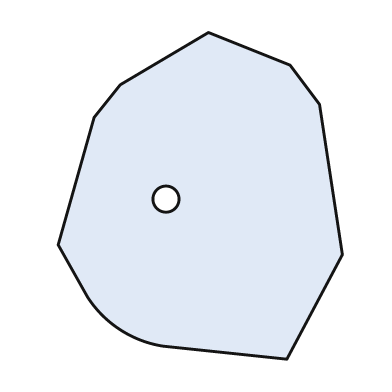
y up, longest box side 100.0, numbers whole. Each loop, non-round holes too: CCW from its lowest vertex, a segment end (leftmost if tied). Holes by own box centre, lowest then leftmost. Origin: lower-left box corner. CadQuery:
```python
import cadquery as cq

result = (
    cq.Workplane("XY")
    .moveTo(70.0, 0.0)
    .lineTo(87.0, 32.0)
    .lineTo(80.0, 78.0)
    .lineTo(71.0, 90.0)
    .lineTo(46.0, 100.0)
    .lineTo(19.0, 84.0)
    .lineTo(11.0, 74.0)
    .lineTo(0.0, 35.0)
    .lineTo(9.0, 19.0)
    .threePointArc((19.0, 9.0), (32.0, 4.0))
    .close()
    .moveTo(33.0, 49.0)
    .circle(4.0)
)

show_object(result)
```